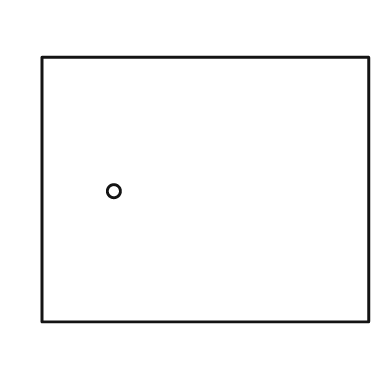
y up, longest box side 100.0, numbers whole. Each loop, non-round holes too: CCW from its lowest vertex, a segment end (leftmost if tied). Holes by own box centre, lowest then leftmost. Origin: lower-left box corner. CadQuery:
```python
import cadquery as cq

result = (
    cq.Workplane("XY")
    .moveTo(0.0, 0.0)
    .lineTo(100.0, 0.0)
    .lineTo(100.0, 81.0)
    .lineTo(0.0, 81.0)
    .close()
    .moveTo(22.0, 40.0)
    .circle(2.0)
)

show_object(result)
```